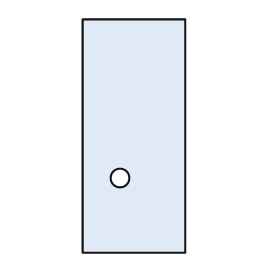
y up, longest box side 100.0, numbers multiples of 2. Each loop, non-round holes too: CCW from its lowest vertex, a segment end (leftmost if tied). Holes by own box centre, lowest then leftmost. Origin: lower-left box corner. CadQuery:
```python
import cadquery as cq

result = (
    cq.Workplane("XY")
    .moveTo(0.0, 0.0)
    .lineTo(44.0, 0.0)
    .lineTo(44.0, 100.0)
    .lineTo(0.0, 100.0)
    .close()
    .moveTo(16.0, 32.0)
    .circle(4.0)
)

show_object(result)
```